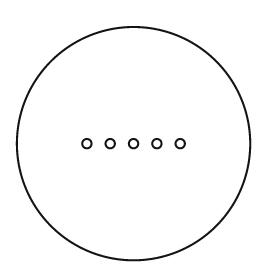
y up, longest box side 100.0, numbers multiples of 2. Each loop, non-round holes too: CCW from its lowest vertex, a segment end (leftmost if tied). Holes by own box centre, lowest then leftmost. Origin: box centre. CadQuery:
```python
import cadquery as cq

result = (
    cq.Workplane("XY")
    .moveTo(0.0, 0.0)
    .circle(50.0)
    .moveTo(-20.0, 0.0)
    .circle(2.0)
    .moveTo(-10.0, 0.0)
    .circle(2.0)
    .moveTo(0.0, 0.0)
    .circle(2.0)
    .moveTo(10.0, 0.0)
    .circle(2.0)
    .moveTo(20.0, 0.0)
    .circle(2.0)
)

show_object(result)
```